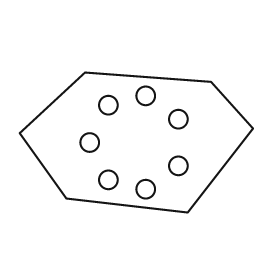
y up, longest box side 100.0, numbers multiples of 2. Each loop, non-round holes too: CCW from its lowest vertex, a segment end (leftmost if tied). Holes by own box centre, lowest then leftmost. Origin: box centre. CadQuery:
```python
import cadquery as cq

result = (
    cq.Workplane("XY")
    .moveTo(22.0, -30.0)
    .lineTo(50.0, 6.0)
    .lineTo(32.0, 26.0)
    .lineTo(-22.0, 30.0)
    .lineTo(-50.0, 4.0)
    .lineTo(-30.0, -24.0)
    .close()
    .moveTo(4.0, -20.0)
    .circle(4.0)
    .moveTo(-12.0, -16.0)
    .circle(4.0)
    .moveTo(18.0, -10.0)
    .circle(4.0)
    .moveTo(-20.0, 0.0)
    .circle(4.0)
    .moveTo(18.0, 10.0)
    .circle(4.0)
    .moveTo(-12.0, 16.0)
    .circle(4.0)
    .moveTo(4.0, 20.0)
    .circle(4.0)
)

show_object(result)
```